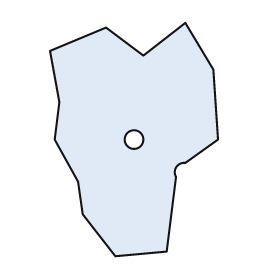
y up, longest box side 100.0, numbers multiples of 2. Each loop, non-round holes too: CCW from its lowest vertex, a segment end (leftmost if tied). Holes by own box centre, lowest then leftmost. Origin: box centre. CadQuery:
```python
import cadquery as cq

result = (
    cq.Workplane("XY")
    .moveTo(-8.0, -50.0)
    .lineTo(14.0, -48.0)
    .lineTo(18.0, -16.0)
    .threePointArc((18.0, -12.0), (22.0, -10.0))
    .lineTo(36.0, 0.0)
    .lineTo(34.0, 30.0)
    .lineTo(22.0, 50.0)
    .lineTo(4.0, 36.0)
    .lineTo(-12.0, 48.0)
    .lineTo(-36.0, 38.0)
    .lineTo(-32.0, 16.0)
    .lineTo(-34.0, 0.0)
    .lineTo(-24.0, -18.0)
    .lineTo(-22.0, -32.0)
    .close()
    .moveTo(0.0, 0.0)
    .circle(4.0)
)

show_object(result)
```